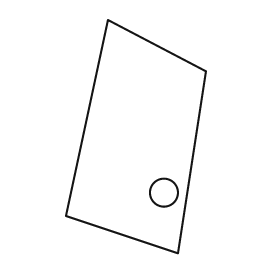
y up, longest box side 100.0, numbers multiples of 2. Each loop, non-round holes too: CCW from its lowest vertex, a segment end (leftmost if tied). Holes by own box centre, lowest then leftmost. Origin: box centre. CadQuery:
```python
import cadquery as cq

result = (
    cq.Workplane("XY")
    .moveTo(18.0, -50.0)
    .lineTo(30.0, 28.0)
    .lineTo(-12.0, 50.0)
    .lineTo(-30.0, -34.0)
    .close()
    .moveTo(12.0, -24.0)
    .circle(6.0)
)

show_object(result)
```